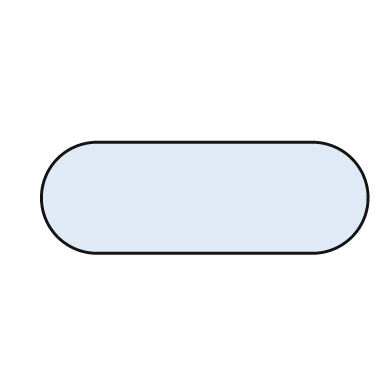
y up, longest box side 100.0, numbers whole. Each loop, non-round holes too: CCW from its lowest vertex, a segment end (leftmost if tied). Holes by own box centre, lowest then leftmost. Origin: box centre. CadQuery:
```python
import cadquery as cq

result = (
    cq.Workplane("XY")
    .moveTo(-33.0, -17.0)
    .lineTo(33.0, -17.0)
    .threePointArc((50.0, 0.0), (33.0, 17.0))
    .lineTo(-33.0, 17.0)
    .threePointArc((-50.0, 0.0), (-33.0, -17.0))
    .close()
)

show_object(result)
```